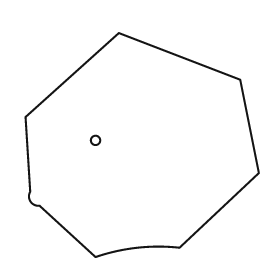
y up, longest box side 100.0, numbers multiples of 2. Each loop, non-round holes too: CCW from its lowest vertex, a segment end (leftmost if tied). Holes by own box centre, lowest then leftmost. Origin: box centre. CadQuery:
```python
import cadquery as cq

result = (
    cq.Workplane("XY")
    .moveTo(-20.0, -48.0)
    .threePointArc((-2.0, -44.0), (16.0, -44.0))
    .lineTo(50.0, -12.0)
    .lineTo(42.0, 28.0)
    .lineTo(-10.0, 48.0)
    .lineTo(-50.0, 12.0)
    .lineTo(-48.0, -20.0)
    .threePointArc((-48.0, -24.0), (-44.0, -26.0))
    .close()
    .moveTo(-20.0, 2.0)
    .circle(2.0)
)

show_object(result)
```